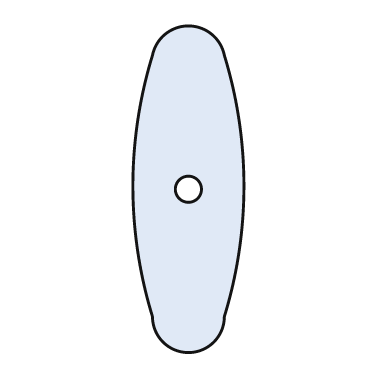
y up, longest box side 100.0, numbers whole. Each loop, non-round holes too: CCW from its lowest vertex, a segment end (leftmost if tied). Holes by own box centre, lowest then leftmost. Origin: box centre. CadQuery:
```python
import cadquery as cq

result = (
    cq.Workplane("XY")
    .moveTo(-11.0, -39.0)
    .threePointArc((0.0, -50.0), (11.0, -39.0))
    .threePointArc((17.0, 1.0), (11.0, 41.0))
    .threePointArc((0.0, 50.0), (-11.0, 41.0))
    .threePointArc((-17.0, 1.0), (-11.0, -39.0))
    .close()
    .moveTo(0.0, 0.0)
    .circle(4.0)
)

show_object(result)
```